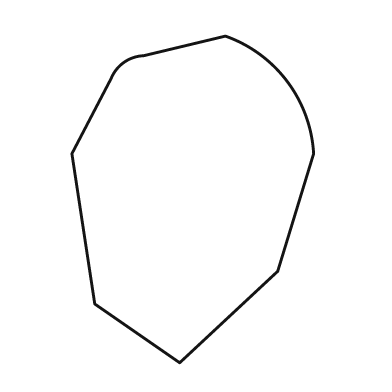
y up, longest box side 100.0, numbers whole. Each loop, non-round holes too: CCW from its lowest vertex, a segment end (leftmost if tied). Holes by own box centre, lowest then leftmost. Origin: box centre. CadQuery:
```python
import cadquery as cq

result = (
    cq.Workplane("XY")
    .moveTo(-4.0, -50.0)
    .lineTo(26.0, -22.0)
    .lineTo(37.0, 14.0)
    .threePointArc((29.0, 36.0), (10.0, 50.0))
    .lineTo(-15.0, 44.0)
    .threePointArc((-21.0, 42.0), (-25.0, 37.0))
    .lineTo(-37.0, 14.0)
    .lineTo(-30.0, -32.0)
    .close()
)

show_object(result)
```